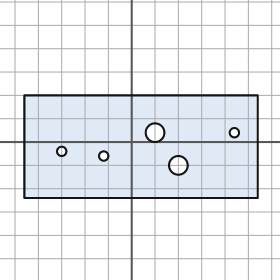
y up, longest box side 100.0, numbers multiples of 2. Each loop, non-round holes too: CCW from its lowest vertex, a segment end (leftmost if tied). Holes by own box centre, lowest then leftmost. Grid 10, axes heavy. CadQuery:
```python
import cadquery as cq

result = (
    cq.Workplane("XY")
    .moveTo(-46.0, -24.0)
    .lineTo(54.0, -24.0)
    .lineTo(54.0, 20.0)
    .lineTo(-46.0, 20.0)
    .close()
    .moveTo(20.0, -10.0)
    .circle(4.0)
    .moveTo(-12.0, -6.0)
    .circle(2.0)
    .moveTo(-30.0, -4.0)
    .circle(2.0)
    .moveTo(10.0, 4.0)
    .circle(4.0)
    .moveTo(44.0, 4.0)
    .circle(2.0)
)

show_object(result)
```